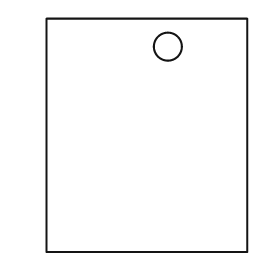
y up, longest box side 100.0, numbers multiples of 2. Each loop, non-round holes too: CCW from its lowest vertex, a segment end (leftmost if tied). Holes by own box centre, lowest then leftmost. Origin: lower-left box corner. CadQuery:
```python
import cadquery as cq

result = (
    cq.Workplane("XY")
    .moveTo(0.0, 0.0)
    .lineTo(86.0, 0.0)
    .lineTo(86.0, 100.0)
    .lineTo(0.0, 100.0)
    .close()
    .moveTo(52.0, 88.0)
    .circle(6.0)
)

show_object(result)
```